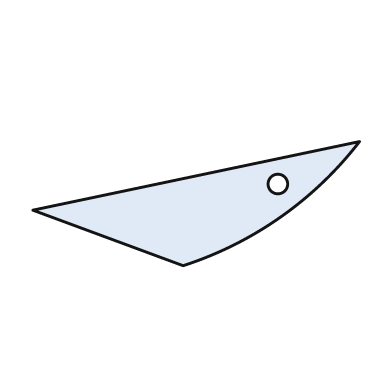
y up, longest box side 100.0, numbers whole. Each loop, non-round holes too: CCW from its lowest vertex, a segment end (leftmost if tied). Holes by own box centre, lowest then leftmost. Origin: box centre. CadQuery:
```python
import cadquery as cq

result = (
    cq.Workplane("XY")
    .moveTo(-4.0, -19.0)
    .threePointArc((26.0, -4.0), (50.0, 19.0))
    .lineTo(-50.0, -2.0)
    .close()
    .moveTo(25.0, 6.0)
    .circle(3.0)
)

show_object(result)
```